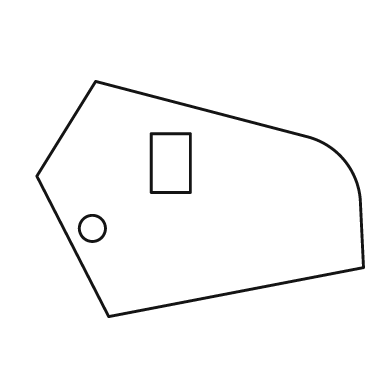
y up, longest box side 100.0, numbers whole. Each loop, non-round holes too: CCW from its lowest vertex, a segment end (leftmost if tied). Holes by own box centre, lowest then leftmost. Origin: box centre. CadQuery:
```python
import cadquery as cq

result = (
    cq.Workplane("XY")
    .moveTo(-28.0, -36.0)
    .lineTo(50.0, -21.0)
    .lineTo(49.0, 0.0)
    .threePointArc((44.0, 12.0), (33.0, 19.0))
    .lineTo(-32.0, 36.0)
    .lineTo(-50.0, 7.0)
    .close()
    .moveTo(-33.0, -9.0)
    .circle(4.0)
    .moveTo(-15.0, 2.0)
    .lineTo(-3.0, 2.0)
    .lineTo(-3.0, 20.0)
    .lineTo(-15.0, 20.0)
    .close()
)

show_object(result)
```